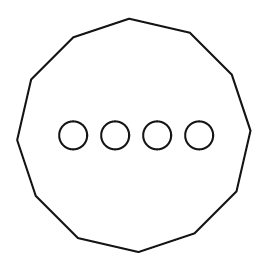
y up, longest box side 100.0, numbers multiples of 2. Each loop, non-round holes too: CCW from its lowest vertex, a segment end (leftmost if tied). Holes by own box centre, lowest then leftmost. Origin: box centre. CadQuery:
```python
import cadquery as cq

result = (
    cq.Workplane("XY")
    .moveTo(2.0, -50.0)
    .lineTo(26.0, -42.0)
    .lineTo(44.0, -24.0)
    .lineTo(50.0, 2.0)
    .lineTo(42.0, 26.0)
    .lineTo(24.0, 44.0)
    .lineTo(-2.0, 50.0)
    .lineTo(-26.0, 42.0)
    .lineTo(-44.0, 24.0)
    .lineTo(-50.0, -2.0)
    .lineTo(-42.0, -26.0)
    .lineTo(-24.0, -44.0)
    .close()
    .moveTo(-26.0, 0.0)
    .circle(6.0)
    .moveTo(-8.0, 0.0)
    .circle(6.0)
    .moveTo(10.0, 0.0)
    .circle(6.0)
    .moveTo(28.0, 0.0)
    .circle(6.0)
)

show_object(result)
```